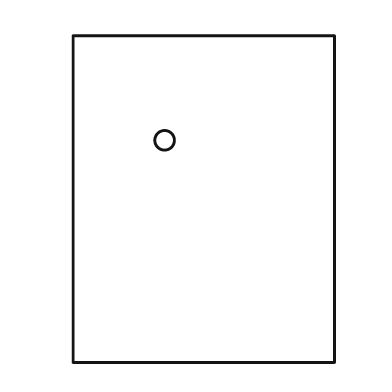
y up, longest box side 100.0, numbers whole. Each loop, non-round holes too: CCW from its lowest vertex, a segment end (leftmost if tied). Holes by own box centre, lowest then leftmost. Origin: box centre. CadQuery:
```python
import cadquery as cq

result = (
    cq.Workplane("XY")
    .moveTo(-40.0, -50.0)
    .lineTo(40.0, -50.0)
    .lineTo(40.0, 50.0)
    .lineTo(-40.0, 50.0)
    .close()
    .moveTo(-12.0, 18.0)
    .circle(3.0)
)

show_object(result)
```